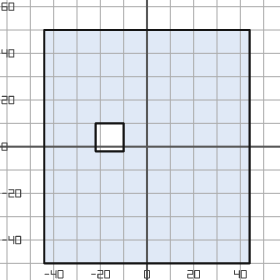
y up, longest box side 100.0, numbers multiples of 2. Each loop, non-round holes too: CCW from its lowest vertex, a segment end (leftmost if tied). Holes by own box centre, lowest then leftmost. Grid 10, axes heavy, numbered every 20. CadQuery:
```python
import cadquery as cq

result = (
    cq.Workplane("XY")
    .moveTo(-44.0, -50.0)
    .lineTo(44.0, -50.0)
    .lineTo(44.0, 50.0)
    .lineTo(-44.0, 50.0)
    .close()
    .moveTo(-22.0, -2.0)
    .lineTo(-10.0, -2.0)
    .lineTo(-10.0, 10.0)
    .lineTo(-22.0, 10.0)
    .close()
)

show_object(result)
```